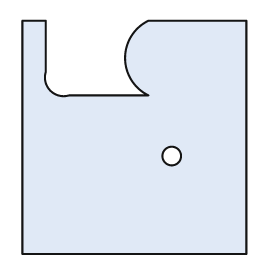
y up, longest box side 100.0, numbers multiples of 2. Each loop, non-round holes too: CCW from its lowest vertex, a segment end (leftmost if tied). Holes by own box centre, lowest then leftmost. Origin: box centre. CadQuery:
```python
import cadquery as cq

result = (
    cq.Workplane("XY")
    .moveTo(-48.0, -50.0)
    .lineTo(48.0, -50.0)
    .lineTo(48.0, 50.0)
    .lineTo(6.0, 50.0)
    .threePointArc((-4.0, 34.0), (6.0, 18.0))
    .lineTo(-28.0, 18.0)
    .threePointArc((-36.0, 20.0), (-38.0, 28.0))
    .lineTo(-38.0, 50.0)
    .lineTo(-48.0, 50.0)
    .close()
    .moveTo(16.0, -8.0)
    .circle(4.0)
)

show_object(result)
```